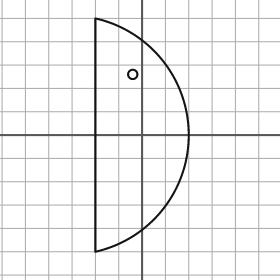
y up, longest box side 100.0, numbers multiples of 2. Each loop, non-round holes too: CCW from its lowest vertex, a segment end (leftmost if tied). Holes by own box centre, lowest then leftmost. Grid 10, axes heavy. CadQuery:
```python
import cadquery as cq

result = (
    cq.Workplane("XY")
    .moveTo(-20.0, -50.0)
    .threePointArc((20.0, 0.0), (-20.0, 50.0))
    .close()
    .moveTo(-4.0, 26.0)
    .circle(2.0)
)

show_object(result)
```